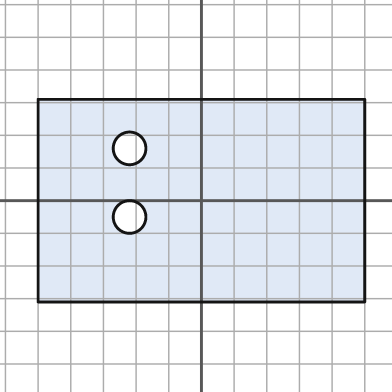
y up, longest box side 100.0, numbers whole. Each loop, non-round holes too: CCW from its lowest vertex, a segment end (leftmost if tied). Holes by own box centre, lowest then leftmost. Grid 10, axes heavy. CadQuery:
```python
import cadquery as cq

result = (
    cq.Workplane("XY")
    .moveTo(-50.0, -31.0)
    .lineTo(50.0, -31.0)
    .lineTo(50.0, 31.0)
    .lineTo(-50.0, 31.0)
    .close()
    .moveTo(-22.0, -5.0)
    .circle(5.0)
    .moveTo(-22.0, 16.0)
    .circle(5.0)
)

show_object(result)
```